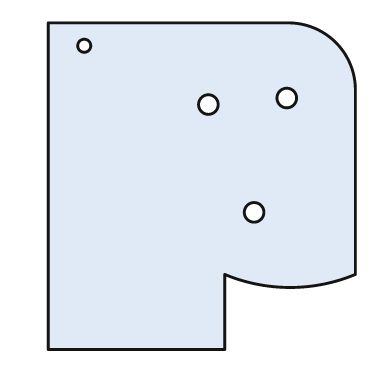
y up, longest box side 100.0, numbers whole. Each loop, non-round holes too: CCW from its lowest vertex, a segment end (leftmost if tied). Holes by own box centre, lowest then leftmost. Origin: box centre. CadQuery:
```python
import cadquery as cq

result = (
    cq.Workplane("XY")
    .moveTo(-47.0, -50.0)
    .lineTo(7.0, -50.0)
    .lineTo(7.0, -27.0)
    .threePointArc((27.0, -31.0), (47.0, -27.0))
    .lineTo(47.0, 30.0)
    .threePointArc((41.0, 44.0), (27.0, 50.0))
    .lineTo(-47.0, 50.0)
    .close()
    .moveTo(16.0, -8.0)
    .circle(3.0)
    .moveTo(2.0, 25.0)
    .circle(3.0)
    .moveTo(26.0, 27.0)
    .circle(3.0)
    .moveTo(-36.0, 43.0)
    .circle(2.0)
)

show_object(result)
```